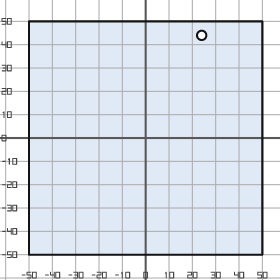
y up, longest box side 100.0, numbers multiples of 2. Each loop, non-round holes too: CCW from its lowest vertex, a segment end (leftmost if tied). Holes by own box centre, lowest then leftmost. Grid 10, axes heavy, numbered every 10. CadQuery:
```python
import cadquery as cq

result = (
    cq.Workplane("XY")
    .moveTo(-50.0, -50.0)
    .lineTo(50.0, -50.0)
    .lineTo(50.0, 50.0)
    .lineTo(-50.0, 50.0)
    .close()
    .moveTo(24.0, 44.0)
    .circle(2.0)
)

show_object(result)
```